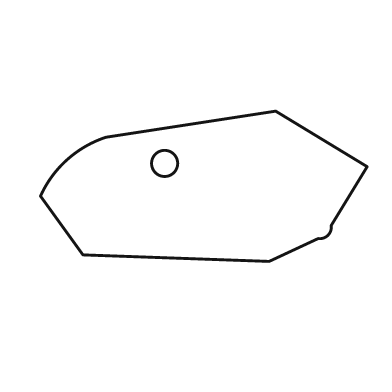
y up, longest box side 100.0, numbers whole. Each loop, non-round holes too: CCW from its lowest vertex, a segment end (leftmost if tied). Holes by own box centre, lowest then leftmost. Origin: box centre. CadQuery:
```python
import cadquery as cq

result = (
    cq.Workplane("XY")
    .moveTo(20.0, -23.0)
    .lineTo(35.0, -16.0)
    .threePointArc((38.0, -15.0), (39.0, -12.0))
    .lineTo(50.0, 6.0)
    .lineTo(22.0, 23.0)
    .lineTo(-30.0, 15.0)
    .threePointArc((-42.0, 8.0), (-50.0, -3.0))
    .lineTo(-37.0, -21.0)
    .close()
    .moveTo(-12.0, 7.0)
    .circle(4.0)
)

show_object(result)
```